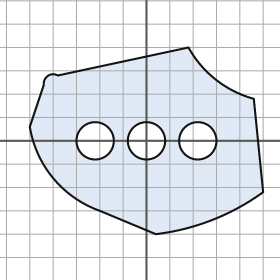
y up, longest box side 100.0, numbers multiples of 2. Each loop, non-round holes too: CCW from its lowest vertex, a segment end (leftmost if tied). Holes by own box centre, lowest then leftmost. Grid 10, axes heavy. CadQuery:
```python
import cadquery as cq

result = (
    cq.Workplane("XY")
    .moveTo(4.0, -40.0)
    .threePointArc((28.0, -34.0), (50.0, -22.0))
    .lineTo(46.0, 18.0)
    .threePointArc((30.0, 26.0), (18.0, 40.0))
    .lineTo(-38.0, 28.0)
    .threePointArc((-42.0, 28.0), (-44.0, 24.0))
    .lineTo(-50.0, 6.0)
    .threePointArc((-40.0, -16.0), (-20.0, -30.0))
    .close()
    .moveTo(-22.0, 0.0)
    .circle(8.0)
    .moveTo(0.0, 0.0)
    .circle(8.0)
    .moveTo(22.0, 0.0)
    .circle(8.0)
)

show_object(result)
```